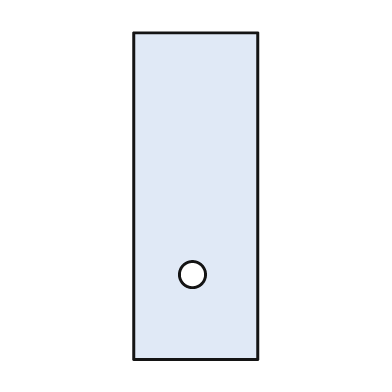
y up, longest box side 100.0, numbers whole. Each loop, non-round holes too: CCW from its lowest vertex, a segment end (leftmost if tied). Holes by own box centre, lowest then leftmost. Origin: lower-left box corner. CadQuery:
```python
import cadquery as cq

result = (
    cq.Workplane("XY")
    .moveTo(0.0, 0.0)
    .lineTo(38.0, 0.0)
    .lineTo(38.0, 100.0)
    .lineTo(0.0, 100.0)
    .close()
    .moveTo(18.0, 26.0)
    .circle(4.0)
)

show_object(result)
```